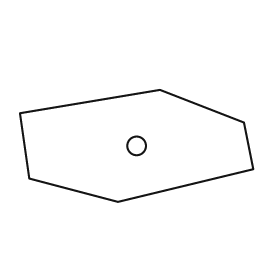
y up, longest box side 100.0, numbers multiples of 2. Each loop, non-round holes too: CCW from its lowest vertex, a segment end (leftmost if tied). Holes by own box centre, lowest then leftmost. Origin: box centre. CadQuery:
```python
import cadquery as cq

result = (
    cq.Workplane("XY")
    .moveTo(-8.0, -24.0)
    .lineTo(50.0, -10.0)
    .lineTo(46.0, 10.0)
    .lineTo(10.0, 24.0)
    .lineTo(-50.0, 14.0)
    .lineTo(-46.0, -14.0)
    .close()
    .moveTo(0.0, 0.0)
    .circle(4.0)
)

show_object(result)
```